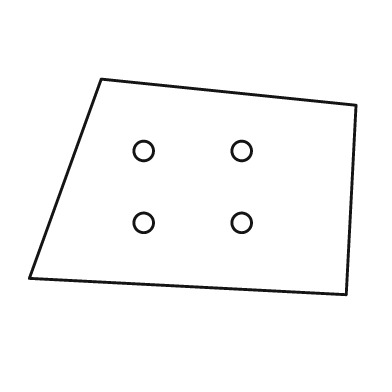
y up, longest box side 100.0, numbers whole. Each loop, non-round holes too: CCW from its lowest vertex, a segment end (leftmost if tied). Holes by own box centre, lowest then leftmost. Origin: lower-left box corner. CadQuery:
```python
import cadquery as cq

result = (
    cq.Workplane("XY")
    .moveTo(97.0, 0.0)
    .lineTo(100.0, 58.0)
    .lineTo(22.0, 66.0)
    .lineTo(0.0, 5.0)
    .close()
    .moveTo(35.0, 22.0)
    .circle(3.0)
    .moveTo(65.0, 22.0)
    .circle(3.0)
    .moveTo(35.0, 44.0)
    .circle(3.0)
    .moveTo(65.0, 44.0)
    .circle(3.0)
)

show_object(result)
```